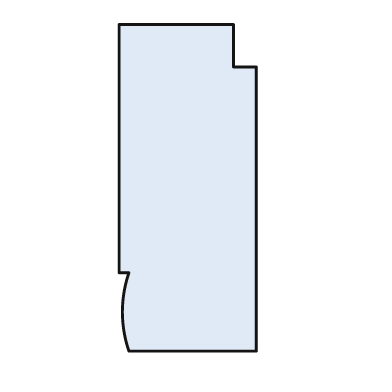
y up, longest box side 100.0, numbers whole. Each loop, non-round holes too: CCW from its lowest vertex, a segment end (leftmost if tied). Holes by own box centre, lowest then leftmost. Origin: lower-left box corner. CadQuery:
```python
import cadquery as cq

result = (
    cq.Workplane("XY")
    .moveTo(3.0, 0.0)
    .lineTo(42.0, 0.0)
    .lineTo(42.0, 87.0)
    .lineTo(35.0, 87.0)
    .lineTo(35.0, 100.0)
    .lineTo(0.0, 100.0)
    .lineTo(0.0, 24.0)
    .lineTo(3.0, 24.0)
    .threePointArc((1.0, 12.0), (3.0, 0.0))
    .close()
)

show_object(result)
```